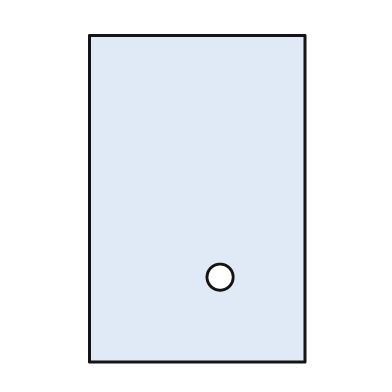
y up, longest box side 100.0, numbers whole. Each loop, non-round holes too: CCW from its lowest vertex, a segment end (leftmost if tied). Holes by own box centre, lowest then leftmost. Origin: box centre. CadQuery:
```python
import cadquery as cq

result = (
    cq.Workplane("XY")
    .moveTo(-33.0, -50.0)
    .lineTo(33.0, -50.0)
    .lineTo(33.0, 50.0)
    .lineTo(-33.0, 50.0)
    .close()
    .moveTo(7.0, -24.0)
    .circle(4.0)
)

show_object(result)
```